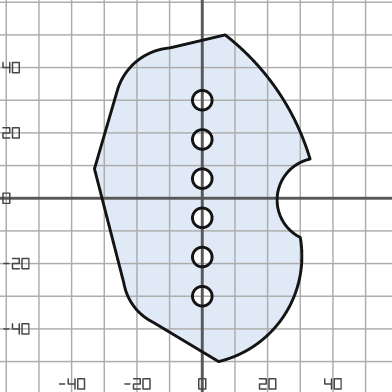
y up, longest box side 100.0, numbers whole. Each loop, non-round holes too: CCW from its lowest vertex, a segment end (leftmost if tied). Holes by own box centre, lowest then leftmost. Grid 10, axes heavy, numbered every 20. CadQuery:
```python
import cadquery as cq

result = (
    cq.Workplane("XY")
    .moveTo(5.0, -50.0)
    .threePointArc((25.0, -36.0), (30.0, -12.0))
    .threePointArc((23.0, 1.0), (33.0, 12.0))
    .threePointArc((23.0, 33.0), (7.0, 50.0))
    .lineTo(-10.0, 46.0)
    .threePointArc((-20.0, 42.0), (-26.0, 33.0))
    .lineTo(-33.0, 9.0)
    .lineTo(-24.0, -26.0)
    .threePointArc((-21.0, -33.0), (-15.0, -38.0))
    .close()
    .moveTo(0.0, -30.0)
    .circle(3.0)
    .moveTo(0.0, -18.0)
    .circle(3.0)
    .moveTo(0.0, -6.0)
    .circle(3.0)
    .moveTo(0.0, 6.0)
    .circle(3.0)
    .moveTo(0.0, 18.0)
    .circle(3.0)
    .moveTo(0.0, 30.0)
    .circle(3.0)
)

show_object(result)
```